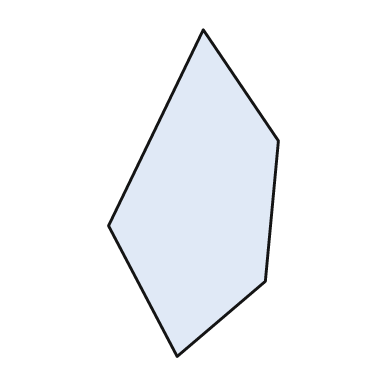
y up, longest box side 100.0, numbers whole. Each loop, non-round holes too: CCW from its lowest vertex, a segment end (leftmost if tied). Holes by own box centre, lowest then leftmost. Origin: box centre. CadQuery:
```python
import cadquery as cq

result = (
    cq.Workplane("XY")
    .moveTo(-5.0, -50.0)
    .lineTo(22.0, -27.0)
    .lineTo(26.0, 16.0)
    .lineTo(3.0, 50.0)
    .lineTo(-26.0, -10.0)
    .close()
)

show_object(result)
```